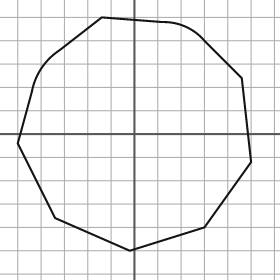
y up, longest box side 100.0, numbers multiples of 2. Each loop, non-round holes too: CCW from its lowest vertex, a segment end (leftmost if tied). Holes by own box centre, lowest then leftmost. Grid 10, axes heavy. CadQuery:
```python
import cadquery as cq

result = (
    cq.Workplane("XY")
    .moveTo(-2.0, -50.0)
    .lineTo(30.0, -40.0)
    .lineTo(50.0, -12.0)
    .lineTo(46.0, 24.0)
    .lineTo(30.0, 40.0)
    .threePointArc((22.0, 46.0), (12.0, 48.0))
    .lineTo(-14.0, 50.0)
    .lineTo(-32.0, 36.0)
    .threePointArc((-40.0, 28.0), (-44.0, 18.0))
    .lineTo(-50.0, -4.0)
    .lineTo(-34.0, -36.0)
    .close()
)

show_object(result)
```